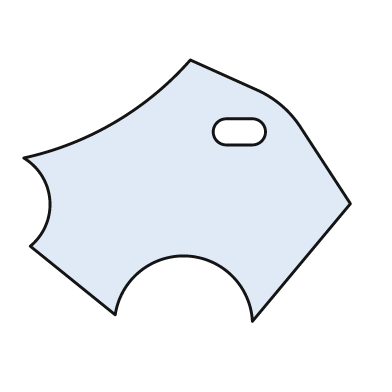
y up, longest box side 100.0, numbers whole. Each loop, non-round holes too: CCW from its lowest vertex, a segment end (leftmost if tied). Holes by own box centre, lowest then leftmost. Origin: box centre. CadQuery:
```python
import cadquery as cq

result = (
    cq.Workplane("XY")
    .moveTo(20.0, -40.0)
    .lineTo(50.0, -4.0)
    .lineTo(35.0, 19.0)
    .threePointArc((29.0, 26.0), (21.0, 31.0))
    .lineTo(1.0, 40.0)
    .threePointArc((-22.0, 21.0), (-50.0, 10.0))
    .threePointArc((-42.0, -3.0), (-48.0, -17.0))
    .lineTo(-22.0, -38.0)
    .threePointArc((0.0, -20.0), (20.0, -40.0))
    .close()
    .moveTo(12.0, 14.0)
    .lineTo(20.0, 14.0)
    .threePointArc((24.0, 18.0), (20.0, 22.0))
    .lineTo(12.0, 22.0)
    .threePointArc((8.0, 18.0), (12.0, 14.0))
    .close()
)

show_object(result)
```